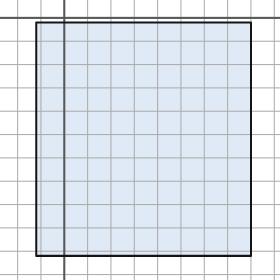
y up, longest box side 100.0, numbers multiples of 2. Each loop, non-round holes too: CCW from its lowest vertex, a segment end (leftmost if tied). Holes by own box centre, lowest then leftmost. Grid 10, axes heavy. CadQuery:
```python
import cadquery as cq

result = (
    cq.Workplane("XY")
    .moveTo(-12.0, -102.0)
    .lineTo(80.0, -102.0)
    .lineTo(80.0, -2.0)
    .lineTo(-12.0, -2.0)
    .close()
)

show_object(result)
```